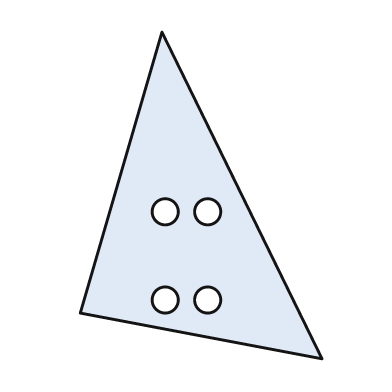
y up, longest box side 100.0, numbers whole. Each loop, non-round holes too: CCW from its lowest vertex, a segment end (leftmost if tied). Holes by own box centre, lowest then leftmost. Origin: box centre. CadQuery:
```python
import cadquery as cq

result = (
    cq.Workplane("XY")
    .moveTo(37.0, -50.0)
    .lineTo(-12.0, 50.0)
    .lineTo(-37.0, -36.0)
    .close()
    .moveTo(-11.0, -32.0)
    .circle(4.0)
    .moveTo(2.0, -32.0)
    .circle(4.0)
    .moveTo(-11.0, -5.0)
    .circle(4.0)
    .moveTo(2.0, -5.0)
    .circle(4.0)
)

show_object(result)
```